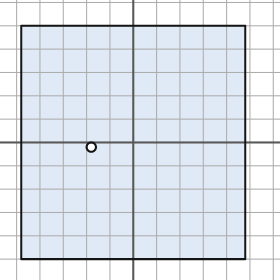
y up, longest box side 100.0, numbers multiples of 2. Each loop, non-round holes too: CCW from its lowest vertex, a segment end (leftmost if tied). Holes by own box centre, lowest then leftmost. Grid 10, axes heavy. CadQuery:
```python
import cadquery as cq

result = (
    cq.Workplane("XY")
    .moveTo(-48.0, -50.0)
    .lineTo(48.0, -50.0)
    .lineTo(48.0, 50.0)
    .lineTo(-48.0, 50.0)
    .close()
    .moveTo(-18.0, -2.0)
    .circle(2.0)
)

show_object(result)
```